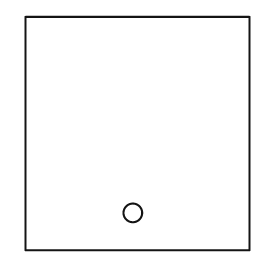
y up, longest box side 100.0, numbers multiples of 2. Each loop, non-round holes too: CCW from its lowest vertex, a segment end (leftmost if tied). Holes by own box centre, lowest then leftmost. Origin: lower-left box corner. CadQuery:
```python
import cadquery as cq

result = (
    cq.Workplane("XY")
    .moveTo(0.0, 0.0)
    .lineTo(96.0, 0.0)
    .lineTo(96.0, 100.0)
    .lineTo(0.0, 100.0)
    .close()
    .moveTo(46.0, 16.0)
    .circle(4.0)
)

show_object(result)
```